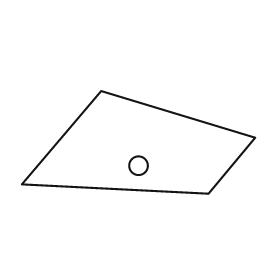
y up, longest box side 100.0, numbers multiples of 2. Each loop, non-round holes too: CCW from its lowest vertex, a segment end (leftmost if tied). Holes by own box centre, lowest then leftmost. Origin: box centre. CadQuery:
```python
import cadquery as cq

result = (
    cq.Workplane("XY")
    .moveTo(30.0, -22.0)
    .lineTo(50.0, 2.0)
    .lineTo(-16.0, 22.0)
    .lineTo(-50.0, -18.0)
    .close()
    .moveTo(0.0, -10.0)
    .circle(4.0)
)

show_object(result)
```